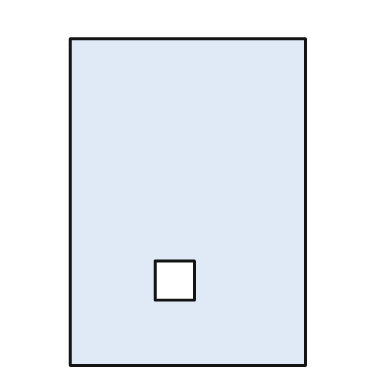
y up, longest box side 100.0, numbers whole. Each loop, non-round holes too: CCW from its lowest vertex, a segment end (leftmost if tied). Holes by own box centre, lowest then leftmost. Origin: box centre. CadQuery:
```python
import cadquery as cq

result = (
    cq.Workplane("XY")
    .moveTo(-36.0, -50.0)
    .lineTo(36.0, -50.0)
    .lineTo(36.0, 50.0)
    .lineTo(-36.0, 50.0)
    .close()
    .moveTo(-10.0, -30.0)
    .lineTo(2.0, -30.0)
    .lineTo(2.0, -18.0)
    .lineTo(-10.0, -18.0)
    .close()
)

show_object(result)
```